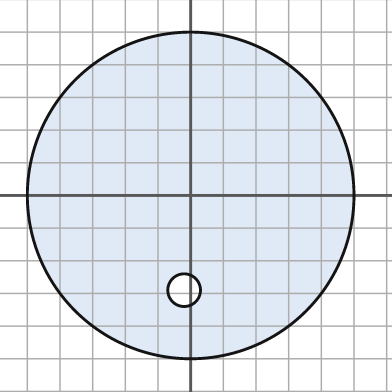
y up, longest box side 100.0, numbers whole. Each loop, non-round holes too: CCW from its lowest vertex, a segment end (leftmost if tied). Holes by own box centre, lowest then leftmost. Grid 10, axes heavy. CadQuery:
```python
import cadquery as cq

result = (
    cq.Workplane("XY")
    .moveTo(0.0, 0.0)
    .circle(50.0)
    .moveTo(-2.0, -29.0)
    .circle(5.0)
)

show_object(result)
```